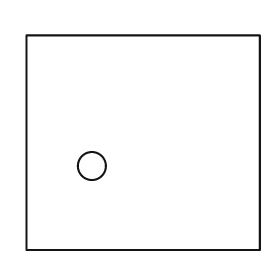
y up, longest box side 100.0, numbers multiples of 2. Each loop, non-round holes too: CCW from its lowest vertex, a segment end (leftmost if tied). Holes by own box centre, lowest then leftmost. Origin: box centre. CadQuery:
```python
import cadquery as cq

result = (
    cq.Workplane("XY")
    .moveTo(-50.0, -46.0)
    .lineTo(50.0, -46.0)
    .lineTo(50.0, 46.0)
    .lineTo(-50.0, 46.0)
    .close()
    .moveTo(-22.0, -10.0)
    .circle(6.0)
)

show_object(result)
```